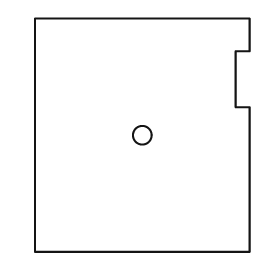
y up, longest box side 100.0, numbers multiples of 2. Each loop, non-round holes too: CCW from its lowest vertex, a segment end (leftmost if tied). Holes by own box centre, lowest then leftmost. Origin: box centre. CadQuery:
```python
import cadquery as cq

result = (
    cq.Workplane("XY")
    .moveTo(-46.0, -50.0)
    .lineTo(46.0, -50.0)
    .lineTo(46.0, 12.0)
    .lineTo(40.0, 12.0)
    .lineTo(40.0, 36.0)
    .lineTo(46.0, 36.0)
    .lineTo(46.0, 50.0)
    .lineTo(-46.0, 50.0)
    .close()
    .moveTo(0.0, 0.0)
    .circle(4.0)
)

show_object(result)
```